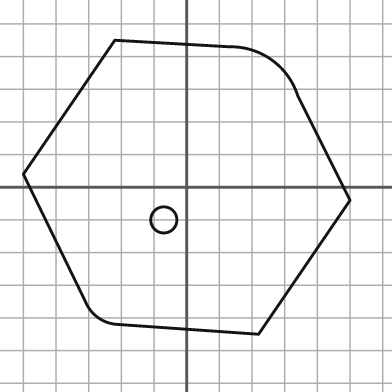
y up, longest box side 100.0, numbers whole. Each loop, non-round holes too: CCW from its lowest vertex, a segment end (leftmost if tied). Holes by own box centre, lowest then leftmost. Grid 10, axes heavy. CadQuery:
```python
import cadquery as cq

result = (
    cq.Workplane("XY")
    .moveTo(22.0, -45.0)
    .lineTo(50.0, -4.0)
    .lineTo(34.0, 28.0)
    .threePointArc((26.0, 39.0), (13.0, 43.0))
    .lineTo(-22.0, 45.0)
    .lineTo(-50.0, 4.0)
    .lineTo(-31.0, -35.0)
    .threePointArc((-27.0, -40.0), (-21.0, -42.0))
    .close()
    .moveTo(-7.0, -10.0)
    .circle(4.0)
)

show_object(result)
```